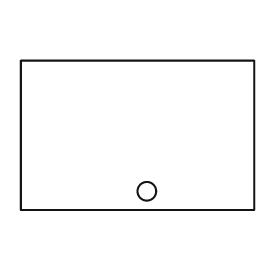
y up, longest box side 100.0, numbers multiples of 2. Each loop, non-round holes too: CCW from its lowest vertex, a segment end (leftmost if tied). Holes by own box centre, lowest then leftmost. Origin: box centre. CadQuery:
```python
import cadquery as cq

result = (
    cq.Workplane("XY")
    .moveTo(-50.0, -32.0)
    .lineTo(50.0, -32.0)
    .lineTo(50.0, 32.0)
    .lineTo(-50.0, 32.0)
    .close()
    .moveTo(4.0, -24.0)
    .circle(4.0)
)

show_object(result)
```